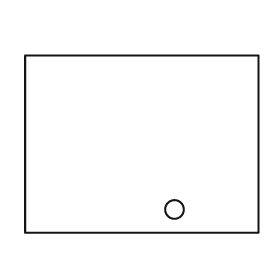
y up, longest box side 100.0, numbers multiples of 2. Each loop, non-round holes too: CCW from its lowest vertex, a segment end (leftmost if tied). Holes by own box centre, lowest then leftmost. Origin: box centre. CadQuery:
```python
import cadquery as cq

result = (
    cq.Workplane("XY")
    .moveTo(-50.0, -38.0)
    .lineTo(50.0, -38.0)
    .lineTo(50.0, 38.0)
    .lineTo(-50.0, 38.0)
    .close()
    .moveTo(14.0, -28.0)
    .circle(4.0)
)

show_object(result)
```